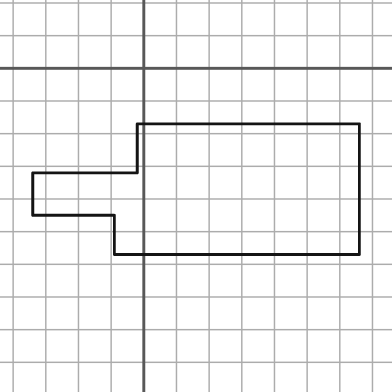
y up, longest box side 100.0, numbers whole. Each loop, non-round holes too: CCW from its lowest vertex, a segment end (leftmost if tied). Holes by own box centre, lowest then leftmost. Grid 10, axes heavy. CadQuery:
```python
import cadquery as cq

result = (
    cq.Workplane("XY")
    .moveTo(-9.0, -57.0)
    .lineTo(66.0, -57.0)
    .lineTo(66.0, -17.0)
    .lineTo(-2.0, -17.0)
    .lineTo(-2.0, -32.0)
    .lineTo(-34.0, -32.0)
    .lineTo(-34.0, -45.0)
    .lineTo(-9.0, -45.0)
    .close()
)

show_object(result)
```